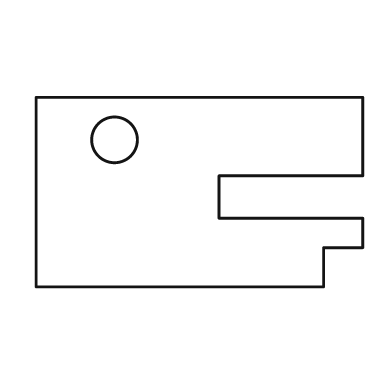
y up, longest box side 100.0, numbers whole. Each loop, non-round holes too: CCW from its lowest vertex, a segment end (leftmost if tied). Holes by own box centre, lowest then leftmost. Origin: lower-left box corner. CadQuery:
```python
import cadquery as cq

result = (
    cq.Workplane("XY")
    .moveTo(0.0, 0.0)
    .lineTo(88.0, 0.0)
    .lineTo(88.0, 12.0)
    .lineTo(100.0, 12.0)
    .lineTo(100.0, 21.0)
    .lineTo(56.0, 21.0)
    .lineTo(56.0, 34.0)
    .lineTo(100.0, 34.0)
    .lineTo(100.0, 58.0)
    .lineTo(0.0, 58.0)
    .close()
    .moveTo(24.0, 45.0)
    .circle(7.0)
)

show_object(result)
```